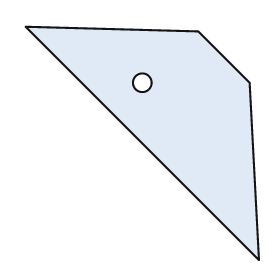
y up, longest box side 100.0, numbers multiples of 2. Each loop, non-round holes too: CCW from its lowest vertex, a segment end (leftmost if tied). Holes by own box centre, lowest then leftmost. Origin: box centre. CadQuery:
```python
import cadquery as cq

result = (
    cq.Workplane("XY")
    .moveTo(50.0, -50.0)
    .lineTo(46.0, 26.0)
    .lineTo(24.0, 48.0)
    .lineTo(-50.0, 50.0)
    .close()
    .moveTo(0.0, 26.0)
    .circle(4.0)
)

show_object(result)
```